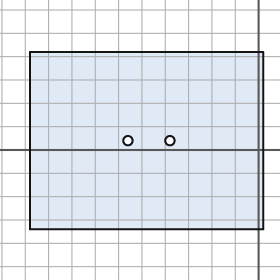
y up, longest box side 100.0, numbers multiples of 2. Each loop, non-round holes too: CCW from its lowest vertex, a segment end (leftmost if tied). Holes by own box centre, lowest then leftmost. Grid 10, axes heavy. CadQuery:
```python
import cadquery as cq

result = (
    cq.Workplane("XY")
    .moveTo(-98.0, -34.0)
    .lineTo(2.0, -34.0)
    .lineTo(2.0, 42.0)
    .lineTo(-98.0, 42.0)
    .close()
    .moveTo(-56.0, 4.0)
    .circle(2.0)
    .moveTo(-38.0, 4.0)
    .circle(2.0)
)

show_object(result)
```